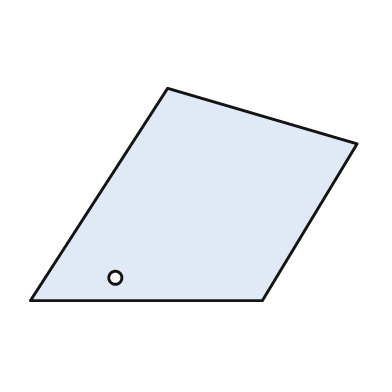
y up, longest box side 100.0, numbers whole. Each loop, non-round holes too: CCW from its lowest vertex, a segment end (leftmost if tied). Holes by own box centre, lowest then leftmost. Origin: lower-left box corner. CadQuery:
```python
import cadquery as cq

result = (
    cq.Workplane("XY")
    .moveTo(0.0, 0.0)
    .lineTo(71.0, 0.0)
    .lineTo(100.0, 48.0)
    .lineTo(42.0, 65.0)
    .close()
    .moveTo(26.0, 7.0)
    .circle(2.0)
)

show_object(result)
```